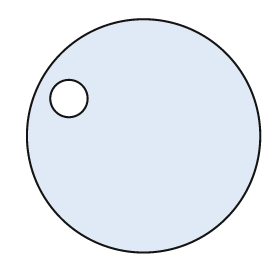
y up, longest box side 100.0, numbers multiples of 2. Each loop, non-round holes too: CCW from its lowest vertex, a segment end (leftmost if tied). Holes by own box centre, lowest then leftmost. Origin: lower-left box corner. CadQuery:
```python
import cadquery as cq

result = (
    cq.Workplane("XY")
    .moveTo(50.0, 50.0)
    .circle(50.0)
    .moveTo(18.0, 66.0)
    .circle(8.0)
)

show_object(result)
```